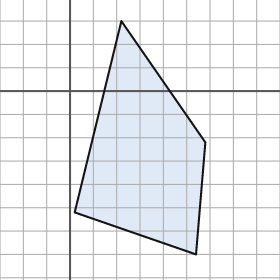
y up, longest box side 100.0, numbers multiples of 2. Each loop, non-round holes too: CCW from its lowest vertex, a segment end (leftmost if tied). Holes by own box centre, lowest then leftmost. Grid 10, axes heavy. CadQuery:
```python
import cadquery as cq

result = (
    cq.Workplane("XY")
    .moveTo(54.0, -70.0)
    .lineTo(58.0, -22.0)
    .lineTo(22.0, 30.0)
    .lineTo(2.0, -52.0)
    .close()
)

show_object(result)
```